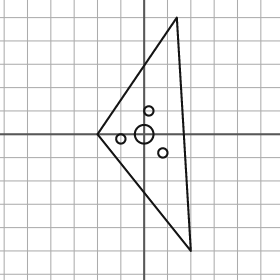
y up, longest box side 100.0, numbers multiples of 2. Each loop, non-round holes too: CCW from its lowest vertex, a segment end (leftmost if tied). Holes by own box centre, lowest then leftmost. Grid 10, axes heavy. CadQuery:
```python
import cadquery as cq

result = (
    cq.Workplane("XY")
    .moveTo(20.0, -50.0)
    .lineTo(14.0, 50.0)
    .lineTo(-20.0, 0.0)
    .close()
    .moveTo(8.0, -8.0)
    .circle(2.0)
    .moveTo(-10.0, -2.0)
    .circle(2.0)
    .moveTo(0.0, 0.0)
    .circle(4.0)
    .moveTo(2.0, 10.0)
    .circle(2.0)
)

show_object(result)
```